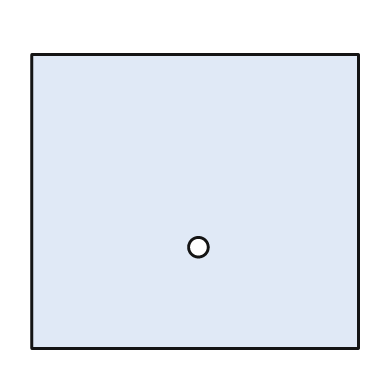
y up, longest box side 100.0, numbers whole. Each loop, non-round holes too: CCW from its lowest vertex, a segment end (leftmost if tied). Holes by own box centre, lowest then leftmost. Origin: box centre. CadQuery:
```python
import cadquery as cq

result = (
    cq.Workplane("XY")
    .moveTo(-50.0, -45.0)
    .lineTo(50.0, -45.0)
    .lineTo(50.0, 45.0)
    .lineTo(-50.0, 45.0)
    .close()
    .moveTo(1.0, -14.0)
    .circle(3.0)
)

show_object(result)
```